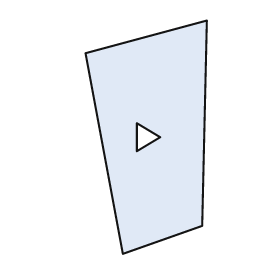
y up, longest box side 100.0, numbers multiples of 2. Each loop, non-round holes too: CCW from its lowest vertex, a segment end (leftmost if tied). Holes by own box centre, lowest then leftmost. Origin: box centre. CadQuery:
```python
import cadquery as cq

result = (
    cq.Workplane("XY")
    .moveTo(-10.0, -50.0)
    .lineTo(24.0, -38.0)
    .lineTo(26.0, 50.0)
    .lineTo(-26.0, 36.0)
    .close()
    .moveTo(-4.0, -6.0)
    .lineTo(6.0, 0.0)
    .lineTo(-4.0, 6.0)
    .close()
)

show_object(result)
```